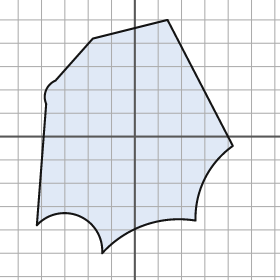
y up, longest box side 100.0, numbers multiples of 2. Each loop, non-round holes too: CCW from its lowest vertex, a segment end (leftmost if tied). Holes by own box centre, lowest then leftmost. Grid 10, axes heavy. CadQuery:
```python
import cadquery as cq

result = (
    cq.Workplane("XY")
    .moveTo(-14.0, -50.0)
    .threePointArc((4.0, -38.0), (26.0, -36.0))
    .threePointArc((30.0, -18.0), (42.0, -4.0))
    .lineTo(14.0, 50.0)
    .lineTo(-18.0, 42.0)
    .lineTo(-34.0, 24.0)
    .threePointArc((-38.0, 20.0), (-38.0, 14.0))
    .lineTo(-42.0, -38.0)
    .threePointArc((-24.0, -34.0), (-14.0, -50.0))
    .close()
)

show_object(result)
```